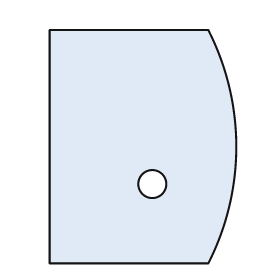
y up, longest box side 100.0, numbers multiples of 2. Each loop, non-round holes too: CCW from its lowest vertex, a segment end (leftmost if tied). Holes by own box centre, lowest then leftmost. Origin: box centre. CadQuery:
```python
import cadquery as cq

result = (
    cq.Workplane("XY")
    .moveTo(-40.0, -50.0)
    .lineTo(28.0, -50.0)
    .threePointArc((40.0, 0.0), (28.0, 50.0))
    .lineTo(-40.0, 50.0)
    .close()
    .moveTo(4.0, -16.0)
    .circle(6.0)
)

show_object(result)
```